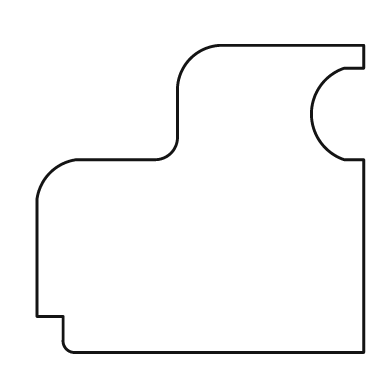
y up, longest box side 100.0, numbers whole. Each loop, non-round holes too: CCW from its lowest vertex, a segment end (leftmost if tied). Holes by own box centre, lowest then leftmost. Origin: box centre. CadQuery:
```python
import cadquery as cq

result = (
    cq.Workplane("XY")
    .moveTo(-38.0, -47.0)
    .lineTo(50.0, -47.0)
    .lineTo(50.0, 12.0)
    .lineTo(44.0, 12.0)
    .threePointArc((34.0, 26.0), (44.0, 40.0))
    .lineTo(50.0, 40.0)
    .lineTo(50.0, 47.0)
    .lineTo(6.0, 47.0)
    .threePointArc((-3.0, 43.0), (-7.0, 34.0))
    .lineTo(-7.0, 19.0)
    .threePointArc((-9.0, 14.0), (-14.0, 12.0))
    .lineTo(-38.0, 12.0)
    .threePointArc((-46.0, 8.0), (-50.0, 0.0))
    .lineTo(-50.0, -36.0)
    .lineTo(-42.0, -36.0)
    .lineTo(-42.0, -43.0)
    .threePointArc((-41.0, -46.0), (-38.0, -47.0))
    .close()
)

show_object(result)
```